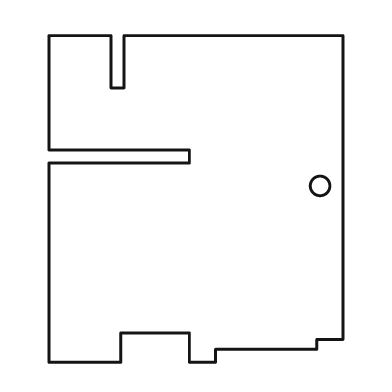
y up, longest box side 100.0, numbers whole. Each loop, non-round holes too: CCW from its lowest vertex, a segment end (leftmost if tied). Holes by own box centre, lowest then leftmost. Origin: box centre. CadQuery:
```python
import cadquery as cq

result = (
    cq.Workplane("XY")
    .moveTo(-45.0, -50.0)
    .lineTo(-23.0, -50.0)
    .lineTo(-23.0, -41.0)
    .lineTo(-2.0, -41.0)
    .lineTo(-2.0, -50.0)
    .lineTo(6.0, -50.0)
    .lineTo(6.0, -46.0)
    .lineTo(37.0, -46.0)
    .lineTo(37.0, -43.0)
    .lineTo(45.0, -43.0)
    .lineTo(45.0, 50.0)
    .lineTo(-22.0, 50.0)
    .lineTo(-22.0, 34.0)
    .lineTo(-26.0, 34.0)
    .lineTo(-26.0, 50.0)
    .lineTo(-45.0, 50.0)
    .lineTo(-45.0, 15.0)
    .lineTo(-2.0, 15.0)
    .lineTo(-2.0, 11.0)
    .lineTo(-45.0, 11.0)
    .close()
    .moveTo(38.0, 4.0)
    .circle(3.0)
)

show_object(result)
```